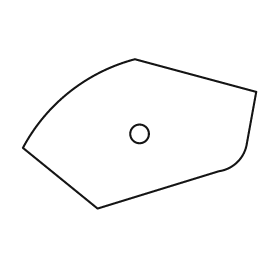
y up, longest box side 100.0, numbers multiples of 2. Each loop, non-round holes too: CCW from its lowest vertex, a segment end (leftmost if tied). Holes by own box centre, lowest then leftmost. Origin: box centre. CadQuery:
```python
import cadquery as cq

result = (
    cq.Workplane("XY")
    .moveTo(-18.0, -32.0)
    .lineTo(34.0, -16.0)
    .threePointArc((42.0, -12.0), (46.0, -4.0))
    .lineTo(50.0, 18.0)
    .lineTo(-2.0, 32.0)
    .threePointArc((-30.0, 18.0), (-50.0, -6.0))
    .close()
    .moveTo(0.0, 0.0)
    .circle(4.0)
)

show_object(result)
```